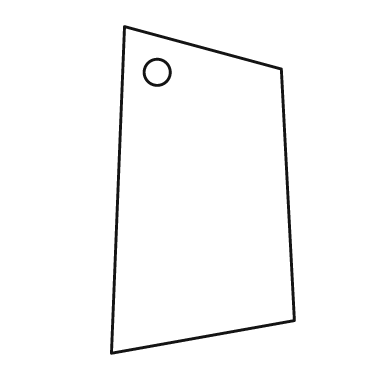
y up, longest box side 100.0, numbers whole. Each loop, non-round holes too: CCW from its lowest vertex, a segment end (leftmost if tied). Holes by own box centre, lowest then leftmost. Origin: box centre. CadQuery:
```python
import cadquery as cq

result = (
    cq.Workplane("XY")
    .moveTo(-28.0, -50.0)
    .lineTo(28.0, -40.0)
    .lineTo(24.0, 37.0)
    .lineTo(-24.0, 50.0)
    .close()
    .moveTo(-14.0, 36.0)
    .circle(4.0)
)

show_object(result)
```